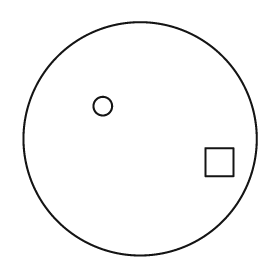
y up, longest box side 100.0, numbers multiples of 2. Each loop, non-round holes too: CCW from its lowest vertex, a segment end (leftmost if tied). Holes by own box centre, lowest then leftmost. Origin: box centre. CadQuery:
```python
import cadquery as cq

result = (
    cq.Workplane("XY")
    .moveTo(0.0, 0.0)
    .circle(50.0)
    .moveTo(28.0, -16.0)
    .lineTo(40.0, -16.0)
    .lineTo(40.0, -4.0)
    .lineTo(28.0, -4.0)
    .close()
    .moveTo(-16.0, 14.0)
    .circle(4.0)
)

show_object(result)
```